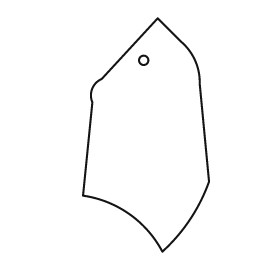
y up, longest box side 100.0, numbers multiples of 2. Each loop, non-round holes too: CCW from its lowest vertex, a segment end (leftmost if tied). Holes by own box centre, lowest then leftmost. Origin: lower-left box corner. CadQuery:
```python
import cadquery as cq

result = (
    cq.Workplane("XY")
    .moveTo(34.0, 0.0)
    .threePointArc((46.0, 14.0), (54.0, 30.0))
    .lineTo(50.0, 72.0)
    .threePointArc((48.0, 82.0), (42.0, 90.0))
    .lineTo(32.0, 100.0)
    .lineTo(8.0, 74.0)
    .threePointArc((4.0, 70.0), (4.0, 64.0))
    .lineTo(0.0, 24.0)
    .threePointArc((20.0, 16.0), (34.0, 0.0))
    .close()
    .moveTo(26.0, 82.0)
    .circle(2.0)
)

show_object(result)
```